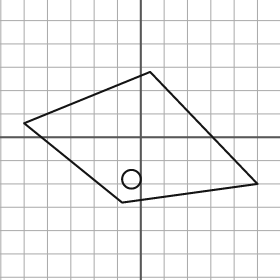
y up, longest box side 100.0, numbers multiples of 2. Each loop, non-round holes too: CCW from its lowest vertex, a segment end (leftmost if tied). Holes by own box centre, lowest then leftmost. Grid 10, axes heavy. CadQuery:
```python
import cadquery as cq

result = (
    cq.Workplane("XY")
    .moveTo(-8.0, -28.0)
    .lineTo(50.0, -20.0)
    .lineTo(4.0, 28.0)
    .lineTo(-50.0, 6.0)
    .close()
    .moveTo(-4.0, -18.0)
    .circle(4.0)
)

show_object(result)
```